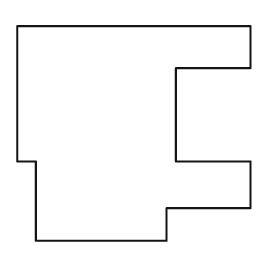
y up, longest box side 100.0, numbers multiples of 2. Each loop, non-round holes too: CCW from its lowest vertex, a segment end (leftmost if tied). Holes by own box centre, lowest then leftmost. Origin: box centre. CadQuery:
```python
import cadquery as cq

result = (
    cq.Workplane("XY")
    .moveTo(-42.0, -46.0)
    .lineTo(14.0, -46.0)
    .lineTo(14.0, -32.0)
    .lineTo(50.0, -32.0)
    .lineTo(50.0, -12.0)
    .lineTo(18.0, -12.0)
    .lineTo(18.0, 28.0)
    .lineTo(50.0, 28.0)
    .lineTo(50.0, 46.0)
    .lineTo(-50.0, 46.0)
    .lineTo(-50.0, -12.0)
    .lineTo(-42.0, -12.0)
    .close()
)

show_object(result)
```